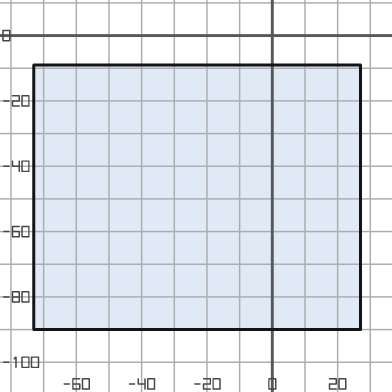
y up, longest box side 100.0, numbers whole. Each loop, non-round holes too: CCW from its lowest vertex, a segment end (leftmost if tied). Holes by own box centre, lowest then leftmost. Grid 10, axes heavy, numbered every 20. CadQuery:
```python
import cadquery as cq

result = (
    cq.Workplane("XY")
    .moveTo(-73.0, -90.0)
    .lineTo(27.0, -90.0)
    .lineTo(27.0, -9.0)
    .lineTo(-73.0, -9.0)
    .close()
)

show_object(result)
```